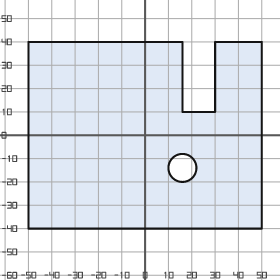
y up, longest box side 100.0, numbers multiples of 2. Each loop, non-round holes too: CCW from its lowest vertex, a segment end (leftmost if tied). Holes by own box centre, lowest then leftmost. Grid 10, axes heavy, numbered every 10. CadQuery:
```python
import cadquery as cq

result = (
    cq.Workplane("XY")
    .moveTo(-50.0, -40.0)
    .lineTo(50.0, -40.0)
    .lineTo(50.0, 40.0)
    .lineTo(30.0, 40.0)
    .lineTo(30.0, 10.0)
    .lineTo(16.0, 10.0)
    .lineTo(16.0, 40.0)
    .lineTo(-50.0, 40.0)
    .close()
    .moveTo(16.0, -14.0)
    .circle(6.0)
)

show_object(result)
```